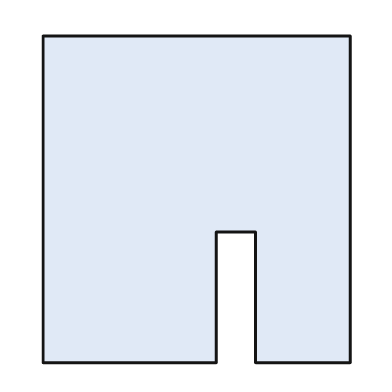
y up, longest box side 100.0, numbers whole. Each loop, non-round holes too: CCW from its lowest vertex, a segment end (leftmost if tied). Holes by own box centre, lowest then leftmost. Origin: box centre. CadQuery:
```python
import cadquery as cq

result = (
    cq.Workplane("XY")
    .moveTo(-47.0, -50.0)
    .lineTo(6.0, -50.0)
    .lineTo(6.0, -10.0)
    .lineTo(18.0, -10.0)
    .lineTo(18.0, -50.0)
    .lineTo(47.0, -50.0)
    .lineTo(47.0, 50.0)
    .lineTo(-47.0, 50.0)
    .close()
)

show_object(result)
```